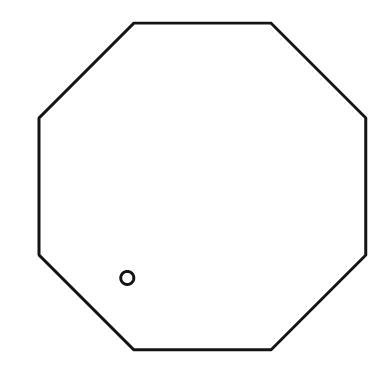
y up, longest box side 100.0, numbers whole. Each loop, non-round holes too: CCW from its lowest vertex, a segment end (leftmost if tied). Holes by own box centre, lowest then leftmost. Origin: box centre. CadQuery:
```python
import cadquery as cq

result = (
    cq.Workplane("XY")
    .moveTo(-21.0, -50.0)
    .lineTo(21.0, -50.0)
    .lineTo(50.0, -21.0)
    .lineTo(50.0, 21.0)
    .lineTo(21.0, 50.0)
    .lineTo(-21.0, 50.0)
    .lineTo(-50.0, 21.0)
    .lineTo(-50.0, -21.0)
    .close()
    .moveTo(-23.0, -28.0)
    .circle(2.0)
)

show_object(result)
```